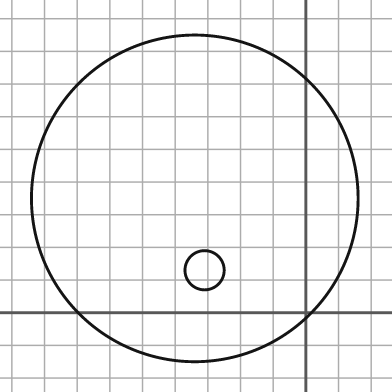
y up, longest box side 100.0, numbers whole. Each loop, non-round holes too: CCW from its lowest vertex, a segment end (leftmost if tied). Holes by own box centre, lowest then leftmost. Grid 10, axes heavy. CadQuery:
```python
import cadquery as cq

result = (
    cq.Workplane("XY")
    .moveTo(-34.0, 35.0)
    .circle(50.0)
    .moveTo(-31.0, 13.0)
    .circle(6.0)
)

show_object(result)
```